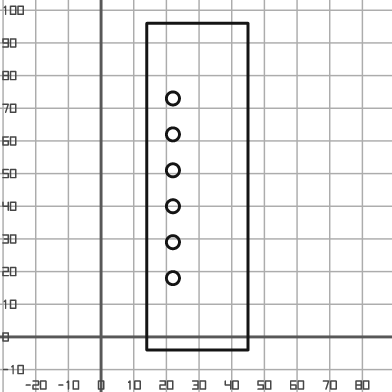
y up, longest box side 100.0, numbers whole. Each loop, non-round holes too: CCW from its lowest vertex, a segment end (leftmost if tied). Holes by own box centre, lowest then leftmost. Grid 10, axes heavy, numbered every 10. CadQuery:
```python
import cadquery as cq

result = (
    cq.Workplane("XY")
    .moveTo(14.0, -4.0)
    .lineTo(45.0, -4.0)
    .lineTo(45.0, 96.0)
    .lineTo(14.0, 96.0)
    .close()
    .moveTo(22.0, 18.0)
    .circle(2.0)
    .moveTo(22.0, 29.0)
    .circle(2.0)
    .moveTo(22.0, 40.0)
    .circle(2.0)
    .moveTo(22.0, 51.0)
    .circle(2.0)
    .moveTo(22.0, 62.0)
    .circle(2.0)
    .moveTo(22.0, 73.0)
    .circle(2.0)
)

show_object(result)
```